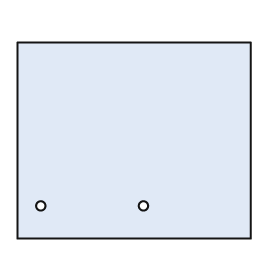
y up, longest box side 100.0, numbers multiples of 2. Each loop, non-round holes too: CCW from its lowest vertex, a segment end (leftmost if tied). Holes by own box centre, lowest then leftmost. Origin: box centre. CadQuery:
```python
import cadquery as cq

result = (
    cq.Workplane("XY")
    .moveTo(-50.0, -42.0)
    .lineTo(50.0, -42.0)
    .lineTo(50.0, 42.0)
    .lineTo(-50.0, 42.0)
    .close()
    .moveTo(-40.0, -28.0)
    .circle(2.0)
    .moveTo(4.0, -28.0)
    .circle(2.0)
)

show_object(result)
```